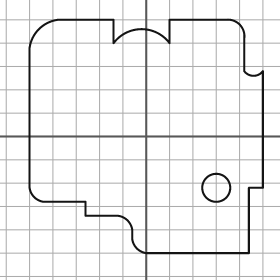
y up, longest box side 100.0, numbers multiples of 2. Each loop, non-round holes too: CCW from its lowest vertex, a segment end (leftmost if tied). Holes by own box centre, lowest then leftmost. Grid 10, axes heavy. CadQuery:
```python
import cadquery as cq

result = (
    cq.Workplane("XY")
    .moveTo(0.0, -50.0)
    .lineTo(44.0, -50.0)
    .lineTo(44.0, -22.0)
    .lineTo(50.0, -22.0)
    .lineTo(50.0, 28.0)
    .threePointArc((46.0, 26.0), (42.0, 28.0))
    .lineTo(42.0, 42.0)
    .threePointArc((40.0, 48.0), (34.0, 50.0))
    .lineTo(10.0, 50.0)
    .lineTo(10.0, 40.0)
    .threePointArc((-2.0, 46.0), (-14.0, 40.0))
    .lineTo(-14.0, 50.0)
    .lineTo(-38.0, 50.0)
    .threePointArc((-46.0, 46.0), (-50.0, 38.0))
    .lineTo(-50.0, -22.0)
    .threePointArc((-48.0, -26.0), (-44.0, -28.0))
    .lineTo(-26.0, -28.0)
    .lineTo(-26.0, -34.0)
    .lineTo(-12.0, -34.0)
    .threePointArc((-8.0, -36.0), (-6.0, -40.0))
    .lineTo(-6.0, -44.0)
    .threePointArc((-4.0, -48.0), (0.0, -50.0))
    .close()
    .moveTo(30.0, -22.0)
    .circle(6.0)
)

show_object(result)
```